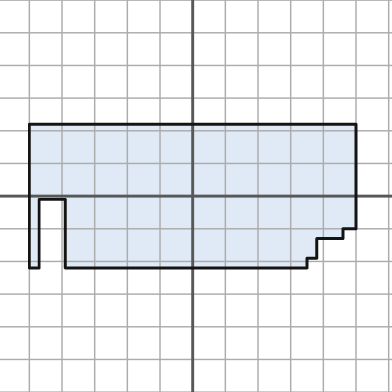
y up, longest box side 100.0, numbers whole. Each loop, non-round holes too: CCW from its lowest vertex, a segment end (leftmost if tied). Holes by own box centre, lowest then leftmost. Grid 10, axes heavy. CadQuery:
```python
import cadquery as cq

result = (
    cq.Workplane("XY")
    .moveTo(-50.0, -22.0)
    .lineTo(-47.0, -22.0)
    .lineTo(-47.0, -1.0)
    .lineTo(-39.0, -1.0)
    .lineTo(-39.0, -22.0)
    .lineTo(35.0, -22.0)
    .lineTo(35.0, -19.0)
    .lineTo(38.0, -19.0)
    .lineTo(38.0, -13.0)
    .lineTo(46.0, -13.0)
    .lineTo(46.0, -10.0)
    .lineTo(50.0, -10.0)
    .lineTo(50.0, 22.0)
    .lineTo(-50.0, 22.0)
    .close()
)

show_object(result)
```